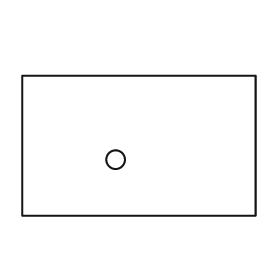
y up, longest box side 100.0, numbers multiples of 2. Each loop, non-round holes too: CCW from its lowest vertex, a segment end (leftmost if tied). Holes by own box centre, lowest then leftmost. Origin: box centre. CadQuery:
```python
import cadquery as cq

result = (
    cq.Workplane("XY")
    .moveTo(-50.0, -30.0)
    .lineTo(50.0, -30.0)
    .lineTo(50.0, 30.0)
    .lineTo(-50.0, 30.0)
    .close()
    .moveTo(-10.0, -6.0)
    .circle(4.0)
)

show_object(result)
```